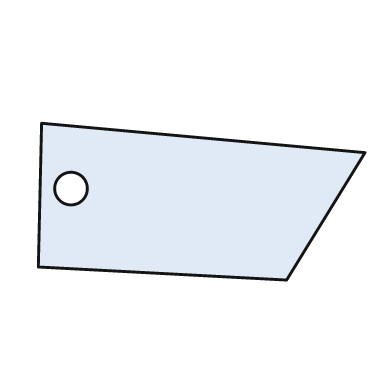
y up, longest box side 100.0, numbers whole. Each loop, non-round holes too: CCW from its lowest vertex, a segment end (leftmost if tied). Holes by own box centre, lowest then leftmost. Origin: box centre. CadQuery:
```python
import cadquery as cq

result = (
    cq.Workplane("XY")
    .moveTo(26.0, -24.0)
    .lineTo(50.0, 15.0)
    .lineTo(-49.0, 24.0)
    .lineTo(-50.0, -20.0)
    .close()
    .moveTo(-40.0, 4.0)
    .circle(5.0)
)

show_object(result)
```